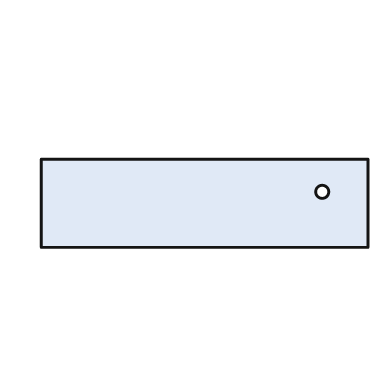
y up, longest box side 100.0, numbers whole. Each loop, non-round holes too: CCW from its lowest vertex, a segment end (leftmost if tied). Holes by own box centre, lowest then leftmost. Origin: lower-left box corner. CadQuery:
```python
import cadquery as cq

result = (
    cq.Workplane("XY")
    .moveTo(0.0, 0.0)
    .lineTo(100.0, 0.0)
    .lineTo(100.0, 27.0)
    .lineTo(0.0, 27.0)
    .close()
    .moveTo(86.0, 17.0)
    .circle(2.0)
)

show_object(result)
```